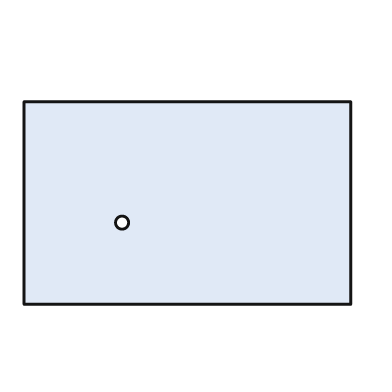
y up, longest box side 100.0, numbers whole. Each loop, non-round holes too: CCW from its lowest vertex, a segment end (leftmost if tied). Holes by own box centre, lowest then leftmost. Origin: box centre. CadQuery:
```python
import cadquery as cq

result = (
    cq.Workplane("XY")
    .moveTo(-50.0, -31.0)
    .lineTo(50.0, -31.0)
    .lineTo(50.0, 31.0)
    .lineTo(-50.0, 31.0)
    .close()
    .moveTo(-20.0, -6.0)
    .circle(2.0)
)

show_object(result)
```